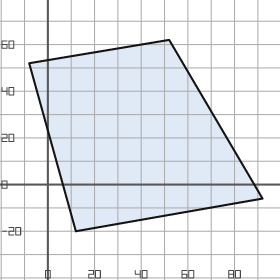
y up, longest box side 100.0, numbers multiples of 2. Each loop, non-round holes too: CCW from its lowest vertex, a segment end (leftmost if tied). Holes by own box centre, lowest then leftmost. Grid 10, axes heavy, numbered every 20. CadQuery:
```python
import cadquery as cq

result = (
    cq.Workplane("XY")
    .moveTo(12.0, -20.0)
    .lineTo(92.0, -6.0)
    .lineTo(52.0, 62.0)
    .lineTo(-8.0, 52.0)
    .close()
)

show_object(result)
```